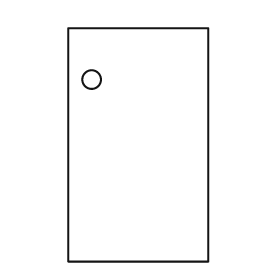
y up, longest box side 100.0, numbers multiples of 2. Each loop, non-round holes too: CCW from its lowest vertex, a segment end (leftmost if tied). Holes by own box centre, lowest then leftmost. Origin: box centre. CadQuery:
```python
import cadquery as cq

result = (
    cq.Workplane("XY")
    .moveTo(-30.0, -50.0)
    .lineTo(30.0, -50.0)
    .lineTo(30.0, 50.0)
    .lineTo(-30.0, 50.0)
    .close()
    .moveTo(-20.0, 28.0)
    .circle(4.0)
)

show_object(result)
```